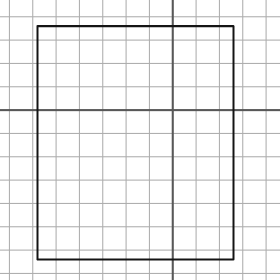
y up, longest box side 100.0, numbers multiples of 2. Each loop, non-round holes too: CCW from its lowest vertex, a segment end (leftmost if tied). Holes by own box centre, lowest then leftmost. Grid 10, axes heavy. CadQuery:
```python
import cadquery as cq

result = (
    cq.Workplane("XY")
    .moveTo(-58.0, -64.0)
    .lineTo(26.0, -64.0)
    .lineTo(26.0, 36.0)
    .lineTo(-58.0, 36.0)
    .close()
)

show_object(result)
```